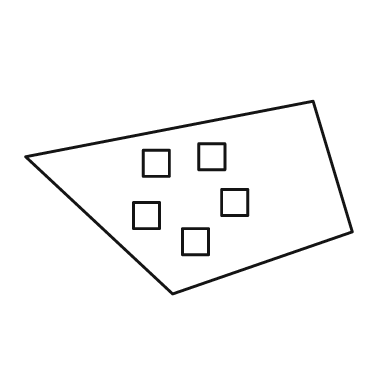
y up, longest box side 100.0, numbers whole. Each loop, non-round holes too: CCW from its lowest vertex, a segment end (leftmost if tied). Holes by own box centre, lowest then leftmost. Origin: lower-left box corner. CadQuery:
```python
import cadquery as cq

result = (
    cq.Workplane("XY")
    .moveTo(45.0, 0.0)
    .lineTo(100.0, 19.0)
    .lineTo(88.0, 59.0)
    .lineTo(0.0, 42.0)
    .close()
    .moveTo(48.0, 12.0)
    .lineTo(56.0, 12.0)
    .lineTo(56.0, 20.0)
    .lineTo(48.0, 20.0)
    .close()
    .moveTo(33.0, 20.0)
    .lineTo(41.0, 20.0)
    .lineTo(41.0, 28.0)
    .lineTo(33.0, 28.0)
    .close()
    .moveTo(60.0, 24.0)
    .lineTo(68.0, 24.0)
    .lineTo(68.0, 32.0)
    .lineTo(60.0, 32.0)
    .close()
    .moveTo(36.0, 36.0)
    .lineTo(44.0, 36.0)
    .lineTo(44.0, 44.0)
    .lineTo(36.0, 44.0)
    .close()
    .moveTo(53.0, 38.0)
    .lineTo(61.0, 38.0)
    .lineTo(61.0, 46.0)
    .lineTo(53.0, 46.0)
    .close()
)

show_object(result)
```